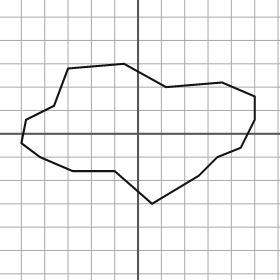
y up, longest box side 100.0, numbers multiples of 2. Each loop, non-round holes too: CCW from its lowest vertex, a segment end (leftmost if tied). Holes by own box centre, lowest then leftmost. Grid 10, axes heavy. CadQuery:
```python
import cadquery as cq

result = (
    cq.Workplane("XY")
    .moveTo(6.0, -30.0)
    .lineTo(26.0, -18.0)
    .lineTo(34.0, -10.0)
    .lineTo(44.0, -6.0)
    .lineTo(50.0, 6.0)
    .lineTo(50.0, 16.0)
    .lineTo(36.0, 22.0)
    .lineTo(12.0, 20.0)
    .lineTo(-6.0, 30.0)
    .lineTo(-30.0, 28.0)
    .lineTo(-36.0, 12.0)
    .lineTo(-48.0, 6.0)
    .lineTo(-50.0, -4.0)
    .lineTo(-42.0, -10.0)
    .lineTo(-28.0, -16.0)
    .lineTo(-10.0, -16.0)
    .close()
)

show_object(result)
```